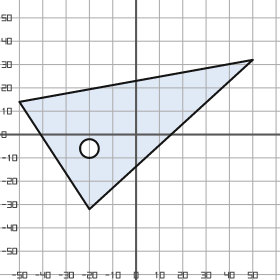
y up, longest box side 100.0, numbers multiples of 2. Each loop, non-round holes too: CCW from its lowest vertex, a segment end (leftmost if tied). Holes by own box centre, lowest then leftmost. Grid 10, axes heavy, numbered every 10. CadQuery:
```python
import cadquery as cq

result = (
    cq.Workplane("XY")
    .moveTo(-20.0, -32.0)
    .lineTo(50.0, 32.0)
    .lineTo(-50.0, 14.0)
    .close()
    .moveTo(-20.0, -6.0)
    .circle(4.0)
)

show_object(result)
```